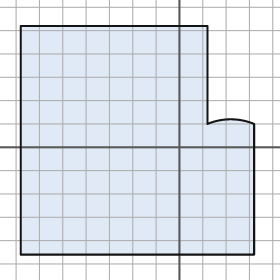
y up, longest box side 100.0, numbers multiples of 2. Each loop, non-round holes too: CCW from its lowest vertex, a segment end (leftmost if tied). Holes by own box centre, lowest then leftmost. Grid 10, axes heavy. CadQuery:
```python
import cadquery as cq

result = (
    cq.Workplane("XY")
    .moveTo(-68.0, -46.0)
    .lineTo(32.0, -46.0)
    .lineTo(32.0, 10.0)
    .threePointArc((22.0, 12.0), (12.0, 10.0))
    .lineTo(12.0, 52.0)
    .lineTo(-68.0, 52.0)
    .close()
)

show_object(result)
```